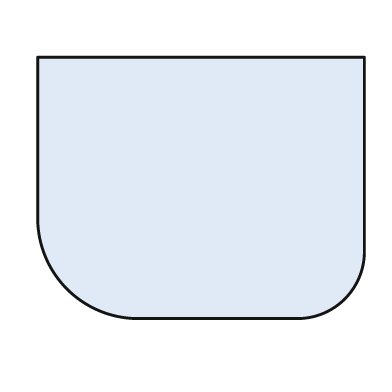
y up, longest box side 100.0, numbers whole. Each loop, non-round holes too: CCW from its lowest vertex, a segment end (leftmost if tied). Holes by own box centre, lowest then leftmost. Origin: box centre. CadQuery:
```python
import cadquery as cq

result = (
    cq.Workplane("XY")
    .moveTo(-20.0, -40.0)
    .lineTo(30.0, -40.0)
    .threePointArc((44.0, -34.0), (50.0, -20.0))
    .lineTo(50.0, 40.0)
    .lineTo(-50.0, 40.0)
    .lineTo(-50.0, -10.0)
    .threePointArc((-41.0, -31.0), (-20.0, -40.0))
    .close()
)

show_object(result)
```